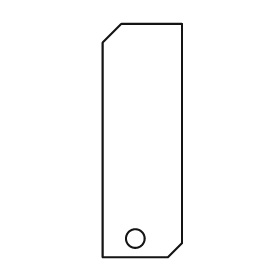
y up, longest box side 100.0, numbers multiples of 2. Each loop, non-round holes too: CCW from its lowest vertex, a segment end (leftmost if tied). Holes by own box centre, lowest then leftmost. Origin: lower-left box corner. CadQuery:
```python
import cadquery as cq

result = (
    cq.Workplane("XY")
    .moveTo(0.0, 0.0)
    .lineTo(28.0, 0.0)
    .lineTo(34.0, 6.0)
    .lineTo(34.0, 100.0)
    .lineTo(8.0, 100.0)
    .lineTo(0.0, 92.0)
    .close()
    .moveTo(14.0, 8.0)
    .circle(4.0)
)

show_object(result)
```